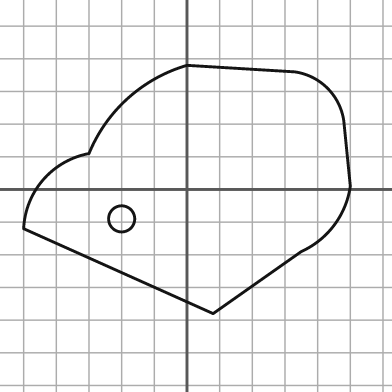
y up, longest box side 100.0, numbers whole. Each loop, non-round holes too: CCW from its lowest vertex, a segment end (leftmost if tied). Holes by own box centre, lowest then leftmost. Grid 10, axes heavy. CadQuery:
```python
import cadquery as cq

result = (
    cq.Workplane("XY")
    .moveTo(8.0, -38.0)
    .lineTo(35.0, -19.0)
    .threePointArc((45.0, -11.0), (50.0, 1.0))
    .lineTo(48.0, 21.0)
    .threePointArc((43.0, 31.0), (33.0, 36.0))
    .lineTo(0.0, 38.0)
    .threePointArc((-18.0, 28.0), (-30.0, 11.0))
    .threePointArc((-44.0, 3.0), (-50.0, -12.0))
    .close()
    .moveTo(-20.0, -9.0)
    .circle(4.0)
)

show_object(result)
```